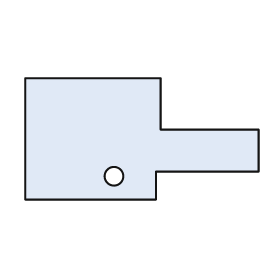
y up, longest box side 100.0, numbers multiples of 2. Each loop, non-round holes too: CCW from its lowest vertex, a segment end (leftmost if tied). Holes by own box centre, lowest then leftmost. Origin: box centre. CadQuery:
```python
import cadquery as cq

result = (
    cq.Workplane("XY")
    .moveTo(-50.0, -26.0)
    .lineTo(6.0, -26.0)
    .lineTo(6.0, -14.0)
    .lineTo(50.0, -14.0)
    .lineTo(50.0, 4.0)
    .lineTo(8.0, 4.0)
    .lineTo(8.0, 26.0)
    .lineTo(-50.0, 26.0)
    .close()
    .moveTo(-12.0, -16.0)
    .circle(4.0)
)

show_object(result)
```